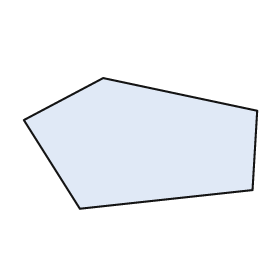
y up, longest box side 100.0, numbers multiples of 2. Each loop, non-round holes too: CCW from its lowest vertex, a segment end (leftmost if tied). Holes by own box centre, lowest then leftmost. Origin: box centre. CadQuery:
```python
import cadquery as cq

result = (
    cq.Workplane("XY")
    .moveTo(-26.0, -28.0)
    .lineTo(48.0, -20.0)
    .lineTo(50.0, 14.0)
    .lineTo(-16.0, 28.0)
    .lineTo(-50.0, 10.0)
    .close()
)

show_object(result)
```